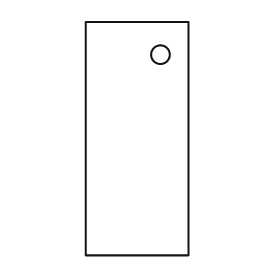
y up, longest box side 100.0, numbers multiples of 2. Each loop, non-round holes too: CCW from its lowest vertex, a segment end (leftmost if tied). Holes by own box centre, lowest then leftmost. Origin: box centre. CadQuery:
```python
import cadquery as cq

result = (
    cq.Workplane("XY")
    .moveTo(-22.0, -50.0)
    .lineTo(22.0, -50.0)
    .lineTo(22.0, 50.0)
    .lineTo(-22.0, 50.0)
    .close()
    .moveTo(10.0, 36.0)
    .circle(4.0)
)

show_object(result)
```